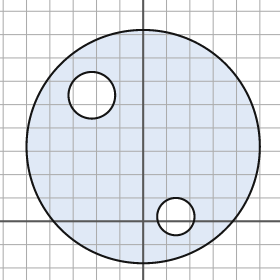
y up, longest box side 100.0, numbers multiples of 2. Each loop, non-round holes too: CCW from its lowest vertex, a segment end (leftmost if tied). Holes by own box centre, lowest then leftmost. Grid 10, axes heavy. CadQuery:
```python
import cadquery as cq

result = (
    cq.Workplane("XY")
    .moveTo(0.0, 32.0)
    .circle(50.0)
    .moveTo(14.0, 2.0)
    .circle(8.0)
    .moveTo(-22.0, 54.0)
    .circle(10.0)
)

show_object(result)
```